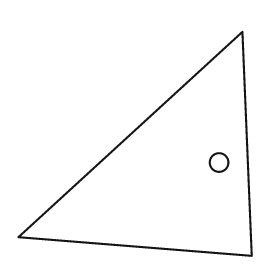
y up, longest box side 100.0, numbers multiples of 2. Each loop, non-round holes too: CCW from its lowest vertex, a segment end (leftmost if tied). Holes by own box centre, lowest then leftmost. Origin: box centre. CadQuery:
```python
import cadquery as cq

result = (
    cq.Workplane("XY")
    .moveTo(50.0, -48.0)
    .lineTo(46.0, 48.0)
    .lineTo(-50.0, -40.0)
    .close()
    .moveTo(36.0, -8.0)
    .circle(4.0)
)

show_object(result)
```